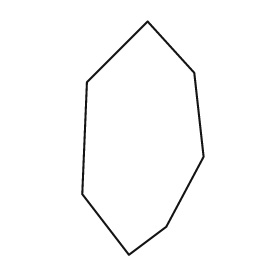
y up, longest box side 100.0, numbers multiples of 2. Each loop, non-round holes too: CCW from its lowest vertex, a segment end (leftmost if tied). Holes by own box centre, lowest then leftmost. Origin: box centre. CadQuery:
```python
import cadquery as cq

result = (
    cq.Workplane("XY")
    .moveTo(-6.0, -50.0)
    .lineTo(10.0, -38.0)
    .lineTo(26.0, -8.0)
    .lineTo(22.0, 28.0)
    .lineTo(2.0, 50.0)
    .lineTo(-24.0, 24.0)
    .lineTo(-26.0, -24.0)
    .close()
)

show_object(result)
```